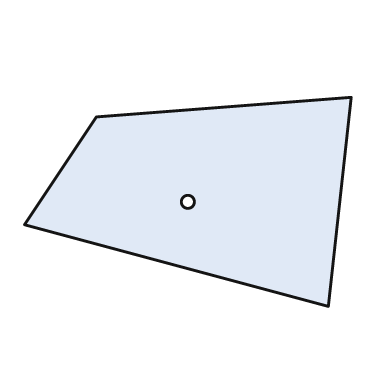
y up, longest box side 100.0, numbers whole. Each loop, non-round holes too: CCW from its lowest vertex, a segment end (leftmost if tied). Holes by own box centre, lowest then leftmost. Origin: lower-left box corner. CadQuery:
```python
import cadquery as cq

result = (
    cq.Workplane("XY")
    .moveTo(93.0, 0.0)
    .lineTo(100.0, 64.0)
    .lineTo(22.0, 58.0)
    .lineTo(0.0, 25.0)
    .close()
    .moveTo(50.0, 32.0)
    .circle(2.0)
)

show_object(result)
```